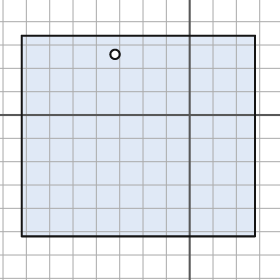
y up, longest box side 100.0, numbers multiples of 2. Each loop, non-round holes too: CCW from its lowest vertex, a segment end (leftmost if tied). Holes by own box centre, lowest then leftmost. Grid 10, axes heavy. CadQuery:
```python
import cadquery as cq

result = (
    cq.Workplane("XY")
    .moveTo(-72.0, -52.0)
    .lineTo(28.0, -52.0)
    .lineTo(28.0, 34.0)
    .lineTo(-72.0, 34.0)
    .close()
    .moveTo(-32.0, 26.0)
    .circle(2.0)
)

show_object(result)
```